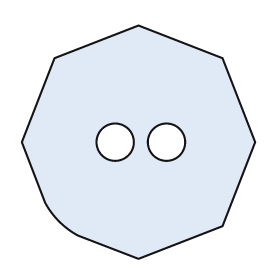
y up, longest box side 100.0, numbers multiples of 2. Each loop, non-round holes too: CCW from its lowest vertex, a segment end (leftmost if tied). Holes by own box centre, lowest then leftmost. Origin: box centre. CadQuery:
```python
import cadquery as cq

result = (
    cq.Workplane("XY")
    .moveTo(0.0, -50.0)
    .lineTo(36.0, -36.0)
    .lineTo(50.0, 0.0)
    .lineTo(36.0, 36.0)
    .lineTo(0.0, 50.0)
    .lineTo(-36.0, 36.0)
    .lineTo(-50.0, 0.0)
    .lineTo(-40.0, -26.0)
    .threePointArc((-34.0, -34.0), (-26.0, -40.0))
    .close()
    .moveTo(-10.0, 0.0)
    .circle(8.0)
    .moveTo(12.0, 0.0)
    .circle(8.0)
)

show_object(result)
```